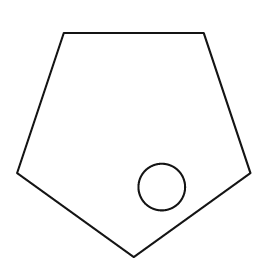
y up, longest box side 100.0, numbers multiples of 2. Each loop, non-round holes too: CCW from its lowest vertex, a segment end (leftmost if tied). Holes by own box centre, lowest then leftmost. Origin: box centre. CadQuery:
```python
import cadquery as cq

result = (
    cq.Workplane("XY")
    .moveTo(0.0, -48.0)
    .lineTo(50.0, -12.0)
    .lineTo(30.0, 48.0)
    .lineTo(-30.0, 48.0)
    .lineTo(-50.0, -12.0)
    .close()
    .moveTo(12.0, -18.0)
    .circle(10.0)
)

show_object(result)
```